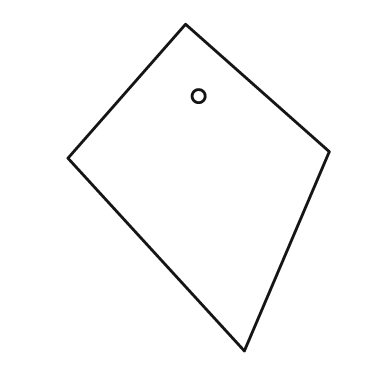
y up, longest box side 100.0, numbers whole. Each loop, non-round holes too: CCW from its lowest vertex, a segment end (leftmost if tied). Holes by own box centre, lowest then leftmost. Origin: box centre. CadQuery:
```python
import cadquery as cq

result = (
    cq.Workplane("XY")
    .moveTo(14.0, -50.0)
    .lineTo(40.0, 11.0)
    .lineTo(-4.0, 50.0)
    .lineTo(-40.0, 9.0)
    .close()
    .moveTo(0.0, 28.0)
    .circle(2.0)
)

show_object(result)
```